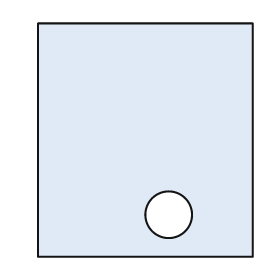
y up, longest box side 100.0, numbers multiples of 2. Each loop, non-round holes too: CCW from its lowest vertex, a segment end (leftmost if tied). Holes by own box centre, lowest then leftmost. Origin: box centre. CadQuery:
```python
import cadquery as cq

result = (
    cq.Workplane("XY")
    .moveTo(-46.0, -50.0)
    .lineTo(46.0, -50.0)
    .lineTo(46.0, 50.0)
    .lineTo(-46.0, 50.0)
    .close()
    .moveTo(10.0, -32.0)
    .circle(10.0)
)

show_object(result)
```